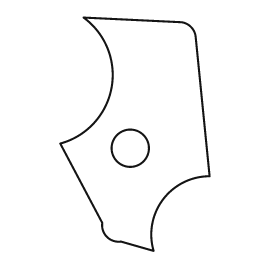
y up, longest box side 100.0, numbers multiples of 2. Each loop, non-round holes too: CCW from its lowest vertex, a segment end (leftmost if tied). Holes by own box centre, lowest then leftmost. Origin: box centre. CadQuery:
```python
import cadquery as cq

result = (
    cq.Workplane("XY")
    .moveTo(8.0, -50.0)
    .threePointArc((12.0, -28.0), (32.0, -18.0))
    .lineTo(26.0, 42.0)
    .threePointArc((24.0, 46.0), (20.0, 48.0))
    .lineTo(-22.0, 50.0)
    .threePointArc((-10.0, 20.0), (-32.0, -4.0))
    .lineTo(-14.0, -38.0)
    .threePointArc((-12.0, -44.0), (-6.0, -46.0))
    .close()
    .moveTo(-2.0, -6.0)
    .circle(8.0)
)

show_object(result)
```